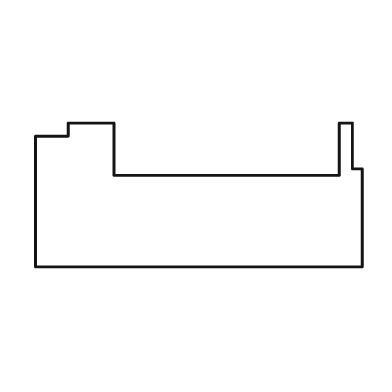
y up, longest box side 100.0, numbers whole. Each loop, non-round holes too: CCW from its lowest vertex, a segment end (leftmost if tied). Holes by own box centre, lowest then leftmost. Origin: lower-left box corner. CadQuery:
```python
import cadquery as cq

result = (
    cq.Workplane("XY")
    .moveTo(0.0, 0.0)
    .lineTo(100.0, 0.0)
    .lineTo(100.0, 30.0)
    .lineTo(97.0, 30.0)
    .lineTo(97.0, 44.0)
    .lineTo(93.0, 44.0)
    .lineTo(93.0, 28.0)
    .lineTo(24.0, 28.0)
    .lineTo(24.0, 44.0)
    .lineTo(10.0, 44.0)
    .lineTo(10.0, 40.0)
    .lineTo(0.0, 40.0)
    .close()
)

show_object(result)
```